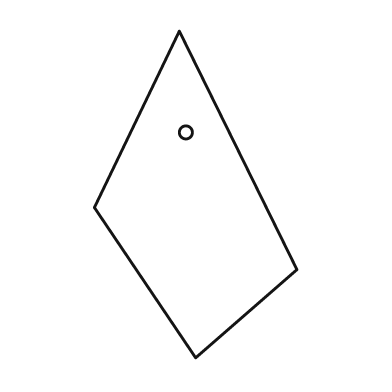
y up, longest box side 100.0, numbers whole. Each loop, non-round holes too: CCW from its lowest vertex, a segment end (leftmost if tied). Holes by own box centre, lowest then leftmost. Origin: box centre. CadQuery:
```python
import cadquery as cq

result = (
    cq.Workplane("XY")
    .moveTo(0.0, -50.0)
    .lineTo(31.0, -23.0)
    .lineTo(-5.0, 50.0)
    .lineTo(-31.0, -4.0)
    .close()
    .moveTo(-3.0, 19.0)
    .circle(2.0)
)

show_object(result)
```